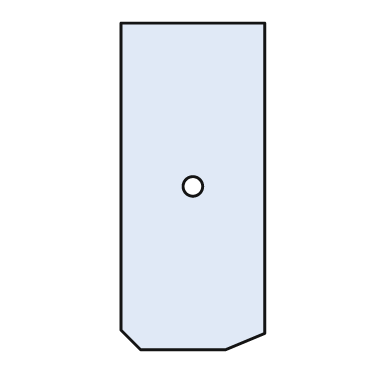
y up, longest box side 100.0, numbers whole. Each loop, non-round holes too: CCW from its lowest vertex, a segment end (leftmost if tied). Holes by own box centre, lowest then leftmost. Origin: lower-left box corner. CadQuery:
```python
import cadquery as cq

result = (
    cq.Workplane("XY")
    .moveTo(6.0, 0.0)
    .lineTo(32.0, 0.0)
    .lineTo(44.0, 5.0)
    .lineTo(44.0, 100.0)
    .lineTo(0.0, 100.0)
    .lineTo(0.0, 6.0)
    .close()
    .moveTo(22.0, 50.0)
    .circle(3.0)
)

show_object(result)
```